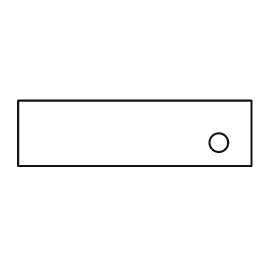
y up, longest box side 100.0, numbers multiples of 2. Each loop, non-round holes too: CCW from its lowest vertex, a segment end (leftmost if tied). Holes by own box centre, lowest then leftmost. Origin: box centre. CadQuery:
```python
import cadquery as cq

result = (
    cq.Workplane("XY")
    .moveTo(-50.0, -14.0)
    .lineTo(50.0, -14.0)
    .lineTo(50.0, 14.0)
    .lineTo(-50.0, 14.0)
    .close()
    .moveTo(36.0, -4.0)
    .circle(4.0)
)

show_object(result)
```